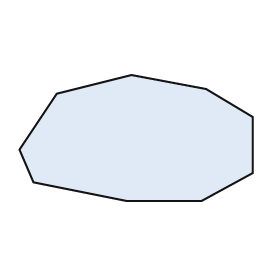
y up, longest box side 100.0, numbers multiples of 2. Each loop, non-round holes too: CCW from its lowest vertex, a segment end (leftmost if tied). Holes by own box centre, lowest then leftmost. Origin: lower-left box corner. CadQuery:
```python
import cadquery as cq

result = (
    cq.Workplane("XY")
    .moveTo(46.0, 0.0)
    .lineTo(78.0, 0.0)
    .lineTo(100.0, 12.0)
    .lineTo(100.0, 36.0)
    .lineTo(80.0, 48.0)
    .lineTo(48.0, 54.0)
    .lineTo(16.0, 46.0)
    .lineTo(0.0, 22.0)
    .lineTo(6.0, 8.0)
    .close()
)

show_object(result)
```